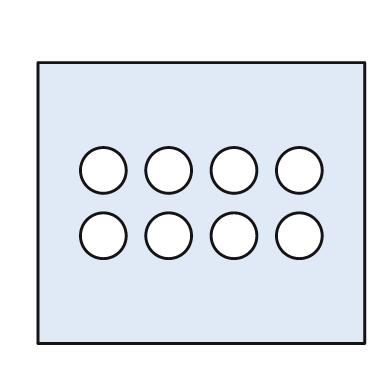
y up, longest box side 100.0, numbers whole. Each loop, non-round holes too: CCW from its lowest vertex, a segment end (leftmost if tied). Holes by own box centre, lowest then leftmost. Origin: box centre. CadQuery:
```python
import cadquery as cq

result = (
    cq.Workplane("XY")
    .moveTo(-50.0, -43.0)
    .lineTo(50.0, -43.0)
    .lineTo(50.0, 43.0)
    .lineTo(-50.0, 43.0)
    .close()
    .moveTo(-30.0, -10.0)
    .circle(7.0)
    .moveTo(-10.0, -10.0)
    .circle(7.0)
    .moveTo(10.0, -10.0)
    .circle(7.0)
    .moveTo(30.0, -10.0)
    .circle(7.0)
    .moveTo(-30.0, 10.0)
    .circle(7.0)
    .moveTo(-10.0, 10.0)
    .circle(7.0)
    .moveTo(10.0, 10.0)
    .circle(7.0)
    .moveTo(30.0, 10.0)
    .circle(7.0)
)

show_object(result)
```